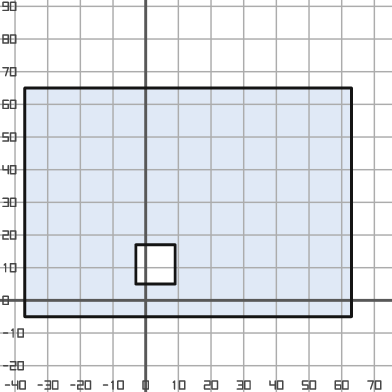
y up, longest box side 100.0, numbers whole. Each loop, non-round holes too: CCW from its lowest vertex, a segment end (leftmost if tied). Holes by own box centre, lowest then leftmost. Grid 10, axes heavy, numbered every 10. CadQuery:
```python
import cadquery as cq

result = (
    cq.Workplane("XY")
    .moveTo(-37.0, -5.0)
    .lineTo(63.0, -5.0)
    .lineTo(63.0, 65.0)
    .lineTo(-37.0, 65.0)
    .close()
    .moveTo(-3.0, 5.0)
    .lineTo(9.0, 5.0)
    .lineTo(9.0, 17.0)
    .lineTo(-3.0, 17.0)
    .close()
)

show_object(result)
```